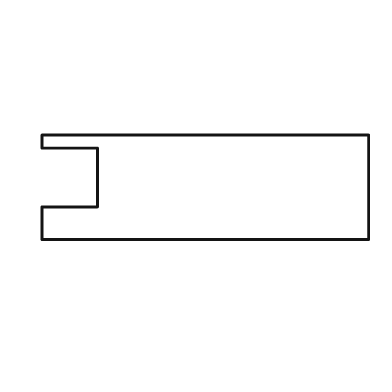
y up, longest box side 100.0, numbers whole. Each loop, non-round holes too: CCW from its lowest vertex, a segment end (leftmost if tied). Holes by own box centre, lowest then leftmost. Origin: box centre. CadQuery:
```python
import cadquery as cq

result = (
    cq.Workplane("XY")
    .moveTo(-50.0, -16.0)
    .lineTo(50.0, -16.0)
    .lineTo(50.0, 16.0)
    .lineTo(-50.0, 16.0)
    .lineTo(-50.0, 12.0)
    .lineTo(-33.0, 12.0)
    .lineTo(-33.0, -6.0)
    .lineTo(-50.0, -6.0)
    .close()
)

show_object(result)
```